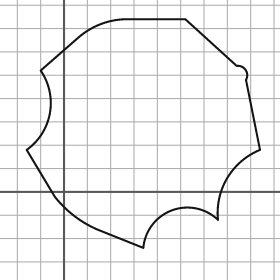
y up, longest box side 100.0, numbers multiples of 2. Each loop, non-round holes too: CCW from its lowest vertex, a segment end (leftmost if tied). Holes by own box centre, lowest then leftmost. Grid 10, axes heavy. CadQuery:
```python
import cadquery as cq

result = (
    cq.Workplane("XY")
    .moveTo(34.0, -24.0)
    .threePointArc((46.0, -8.0), (66.0, -12.0))
    .threePointArc((70.0, 6.0), (84.0, 18.0))
    .lineTo(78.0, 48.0)
    .threePointArc((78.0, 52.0), (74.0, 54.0))
    .lineTo(52.0, 74.0)
    .lineTo(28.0, 74.0)
    .threePointArc((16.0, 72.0), (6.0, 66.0))
    .lineTo(-10.0, 52.0)
    .threePointArc((-6.0, 34.0), (-16.0, 18.0))
    .lineTo(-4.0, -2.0)
    .threePointArc((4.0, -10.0), (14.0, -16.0))
    .close()
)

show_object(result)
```